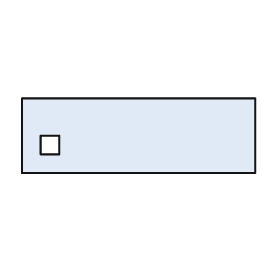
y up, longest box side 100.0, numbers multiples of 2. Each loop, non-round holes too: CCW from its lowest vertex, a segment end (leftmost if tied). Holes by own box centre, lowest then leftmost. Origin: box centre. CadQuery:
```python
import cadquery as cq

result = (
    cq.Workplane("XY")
    .moveTo(-50.0, -16.0)
    .lineTo(50.0, -16.0)
    .lineTo(50.0, 16.0)
    .lineTo(-50.0, 16.0)
    .close()
    .moveTo(-42.0, -8.0)
    .lineTo(-34.0, -8.0)
    .lineTo(-34.0, 0.0)
    .lineTo(-42.0, 0.0)
    .close()
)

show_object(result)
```